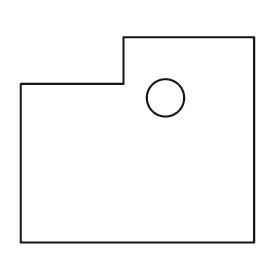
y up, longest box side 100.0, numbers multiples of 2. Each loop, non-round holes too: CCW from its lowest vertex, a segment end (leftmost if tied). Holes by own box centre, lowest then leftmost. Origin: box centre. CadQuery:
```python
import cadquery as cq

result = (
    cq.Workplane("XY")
    .moveTo(-50.0, -44.0)
    .lineTo(50.0, -44.0)
    .lineTo(50.0, 44.0)
    .lineTo(-6.0, 44.0)
    .lineTo(-6.0, 24.0)
    .lineTo(-50.0, 24.0)
    .close()
    .moveTo(12.0, 18.0)
    .circle(8.0)
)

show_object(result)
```